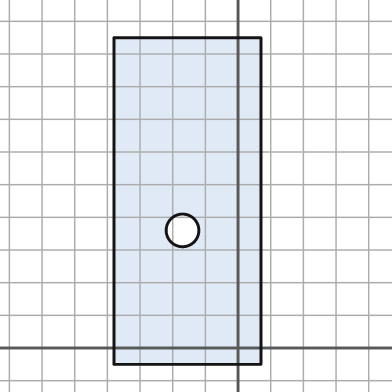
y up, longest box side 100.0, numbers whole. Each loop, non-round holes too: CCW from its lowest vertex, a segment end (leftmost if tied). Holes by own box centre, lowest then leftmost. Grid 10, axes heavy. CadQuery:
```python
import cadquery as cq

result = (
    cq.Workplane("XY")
    .moveTo(-38.0, -5.0)
    .lineTo(7.0, -5.0)
    .lineTo(7.0, 95.0)
    .lineTo(-38.0, 95.0)
    .close()
    .moveTo(-17.0, 36.0)
    .circle(5.0)
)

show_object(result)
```